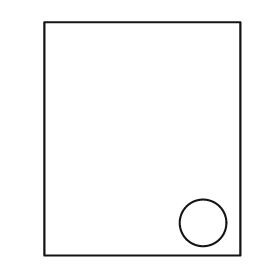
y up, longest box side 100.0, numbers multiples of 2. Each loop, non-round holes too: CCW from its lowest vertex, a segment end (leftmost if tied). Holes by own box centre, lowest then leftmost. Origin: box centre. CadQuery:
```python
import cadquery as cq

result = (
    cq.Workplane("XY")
    .moveTo(-42.0, -50.0)
    .lineTo(42.0, -50.0)
    .lineTo(42.0, 50.0)
    .lineTo(-42.0, 50.0)
    .close()
    .moveTo(26.0, -36.0)
    .circle(10.0)
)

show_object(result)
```